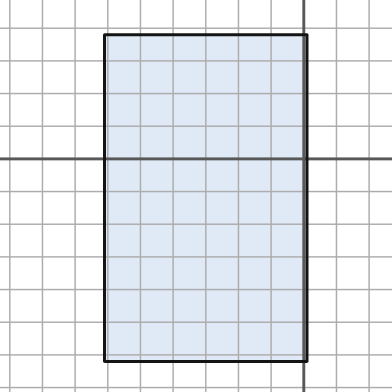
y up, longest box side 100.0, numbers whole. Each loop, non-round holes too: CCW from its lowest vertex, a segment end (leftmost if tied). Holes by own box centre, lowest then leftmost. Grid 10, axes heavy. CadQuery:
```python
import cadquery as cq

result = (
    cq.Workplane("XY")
    .moveTo(-61.0, -62.0)
    .lineTo(1.0, -62.0)
    .lineTo(1.0, 38.0)
    .lineTo(-61.0, 38.0)
    .close()
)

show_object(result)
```